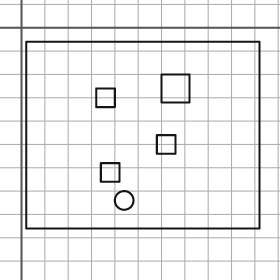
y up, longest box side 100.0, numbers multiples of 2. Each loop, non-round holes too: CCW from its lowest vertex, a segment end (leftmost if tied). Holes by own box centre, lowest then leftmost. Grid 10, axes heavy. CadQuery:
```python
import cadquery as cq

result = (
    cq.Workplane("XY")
    .moveTo(2.0, -86.0)
    .lineTo(102.0, -86.0)
    .lineTo(102.0, -6.0)
    .lineTo(2.0, -6.0)
    .close()
    .moveTo(44.0, -74.0)
    .circle(4.0)
    .moveTo(34.0, -66.0)
    .lineTo(42.0, -66.0)
    .lineTo(42.0, -58.0)
    .lineTo(34.0, -58.0)
    .close()
    .moveTo(58.0, -54.0)
    .lineTo(66.0, -54.0)
    .lineTo(66.0, -46.0)
    .lineTo(58.0, -46.0)
    .close()
    .moveTo(32.0, -34.0)
    .lineTo(40.0, -34.0)
    .lineTo(40.0, -26.0)
    .lineTo(32.0, -26.0)
    .close()
    .moveTo(60.0, -32.0)
    .lineTo(72.0, -32.0)
    .lineTo(72.0, -20.0)
    .lineTo(60.0, -20.0)
    .close()
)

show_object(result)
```